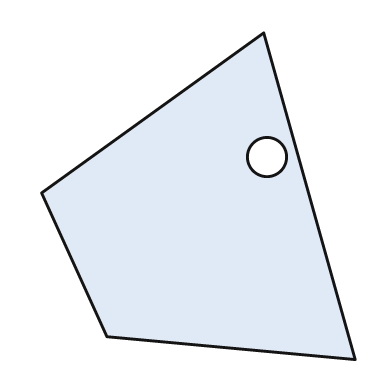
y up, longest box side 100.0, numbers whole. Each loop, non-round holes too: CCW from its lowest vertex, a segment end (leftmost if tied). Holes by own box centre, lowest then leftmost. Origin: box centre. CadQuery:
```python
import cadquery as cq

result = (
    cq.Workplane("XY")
    .moveTo(48.0, -50.0)
    .lineTo(20.0, 50.0)
    .lineTo(-48.0, 1.0)
    .lineTo(-28.0, -43.0)
    .close()
    .moveTo(21.0, 12.0)
    .circle(6.0)
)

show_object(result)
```